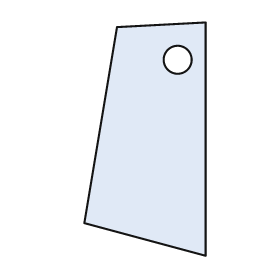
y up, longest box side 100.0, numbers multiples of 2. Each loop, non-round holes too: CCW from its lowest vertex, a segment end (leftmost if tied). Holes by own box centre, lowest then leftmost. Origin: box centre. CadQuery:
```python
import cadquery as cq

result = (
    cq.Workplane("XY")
    .moveTo(26.0, -50.0)
    .lineTo(26.0, 50.0)
    .lineTo(-12.0, 48.0)
    .lineTo(-26.0, -36.0)
    .close()
    .moveTo(14.0, 34.0)
    .circle(6.0)
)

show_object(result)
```